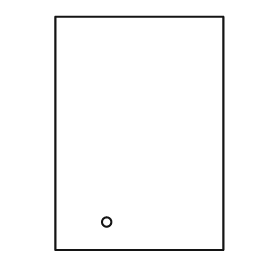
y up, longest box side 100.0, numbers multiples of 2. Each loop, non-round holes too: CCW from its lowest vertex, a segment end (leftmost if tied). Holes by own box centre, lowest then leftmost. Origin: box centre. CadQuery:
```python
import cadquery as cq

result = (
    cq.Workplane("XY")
    .moveTo(-36.0, -50.0)
    .lineTo(36.0, -50.0)
    .lineTo(36.0, 50.0)
    .lineTo(-36.0, 50.0)
    .close()
    .moveTo(-14.0, -38.0)
    .circle(2.0)
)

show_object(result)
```